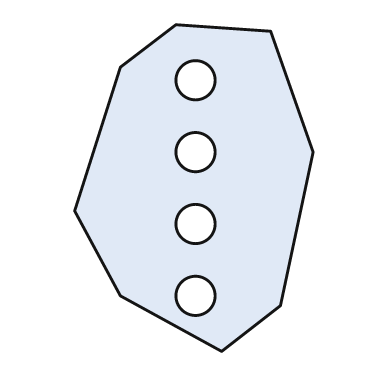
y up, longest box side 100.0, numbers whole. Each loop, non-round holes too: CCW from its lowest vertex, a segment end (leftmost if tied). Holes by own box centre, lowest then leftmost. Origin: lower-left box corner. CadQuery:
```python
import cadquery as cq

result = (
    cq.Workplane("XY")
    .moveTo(45.0, 0.0)
    .lineTo(63.0, 14.0)
    .lineTo(73.0, 61.0)
    .lineTo(60.0, 98.0)
    .lineTo(31.0, 100.0)
    .lineTo(14.0, 87.0)
    .lineTo(0.0, 43.0)
    .lineTo(14.0, 17.0)
    .close()
    .moveTo(37.0, 17.0)
    .circle(6.0)
    .moveTo(37.0, 39.0)
    .circle(6.0)
    .moveTo(37.0, 61.0)
    .circle(6.0)
    .moveTo(37.0, 83.0)
    .circle(6.0)
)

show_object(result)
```